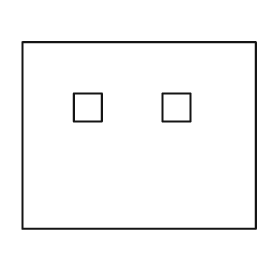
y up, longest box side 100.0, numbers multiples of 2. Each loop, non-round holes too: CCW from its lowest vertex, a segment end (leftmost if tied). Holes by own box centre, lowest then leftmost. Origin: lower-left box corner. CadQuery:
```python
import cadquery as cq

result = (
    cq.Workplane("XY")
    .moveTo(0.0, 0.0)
    .lineTo(100.0, 0.0)
    .lineTo(100.0, 80.0)
    .lineTo(0.0, 80.0)
    .close()
    .moveTo(22.0, 46.0)
    .lineTo(34.0, 46.0)
    .lineTo(34.0, 58.0)
    .lineTo(22.0, 58.0)
    .close()
    .moveTo(60.0, 46.0)
    .lineTo(72.0, 46.0)
    .lineTo(72.0, 58.0)
    .lineTo(60.0, 58.0)
    .close()
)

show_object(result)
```